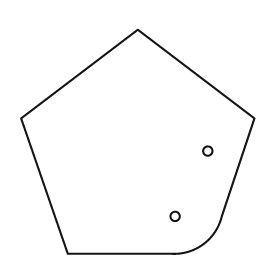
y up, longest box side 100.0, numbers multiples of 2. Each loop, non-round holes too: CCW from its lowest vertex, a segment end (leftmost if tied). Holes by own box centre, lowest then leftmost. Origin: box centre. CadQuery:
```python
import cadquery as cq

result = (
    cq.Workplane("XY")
    .moveTo(-30.0, -48.0)
    .lineTo(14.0, -48.0)
    .threePointArc((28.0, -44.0), (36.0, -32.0))
    .lineTo(50.0, 10.0)
    .lineTo(0.0, 48.0)
    .lineTo(-50.0, 10.0)
    .close()
    .moveTo(16.0, -32.0)
    .circle(2.0)
    .moveTo(30.0, -4.0)
    .circle(2.0)
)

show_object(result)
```